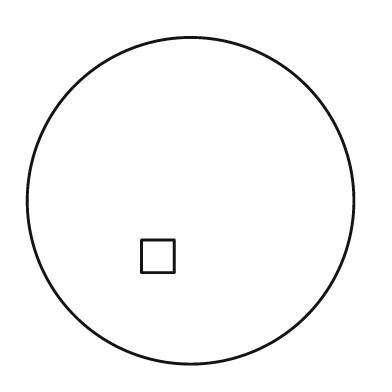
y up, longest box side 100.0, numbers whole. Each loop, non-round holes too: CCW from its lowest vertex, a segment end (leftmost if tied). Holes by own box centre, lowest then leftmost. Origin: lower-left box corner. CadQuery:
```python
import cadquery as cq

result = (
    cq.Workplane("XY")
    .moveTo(50.0, 50.0)
    .circle(50.0)
    .moveTo(35.0, 28.0)
    .lineTo(45.0, 28.0)
    .lineTo(45.0, 38.0)
    .lineTo(35.0, 38.0)
    .close()
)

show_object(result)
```